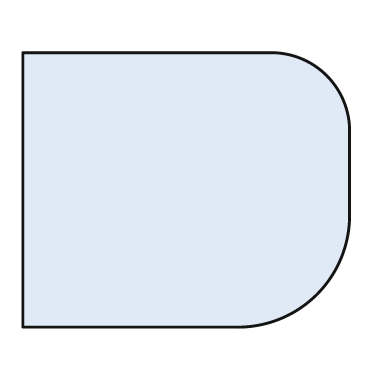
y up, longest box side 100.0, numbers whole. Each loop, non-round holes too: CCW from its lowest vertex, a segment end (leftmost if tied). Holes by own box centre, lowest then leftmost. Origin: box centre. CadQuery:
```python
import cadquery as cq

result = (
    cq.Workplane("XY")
    .moveTo(-50.0, -42.0)
    .lineTo(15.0, -42.0)
    .threePointArc((40.0, -32.0), (50.0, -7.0))
    .lineTo(50.0, 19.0)
    .threePointArc((43.0, 35.0), (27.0, 42.0))
    .lineTo(-50.0, 42.0)
    .close()
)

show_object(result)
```